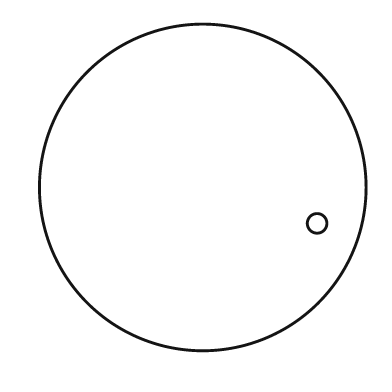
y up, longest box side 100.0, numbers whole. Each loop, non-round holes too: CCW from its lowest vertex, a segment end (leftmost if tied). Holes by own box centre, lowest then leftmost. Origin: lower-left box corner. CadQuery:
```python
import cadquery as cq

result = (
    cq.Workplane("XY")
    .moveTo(50.0, 50.0)
    .circle(50.0)
    .moveTo(85.0, 39.0)
    .circle(3.0)
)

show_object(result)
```